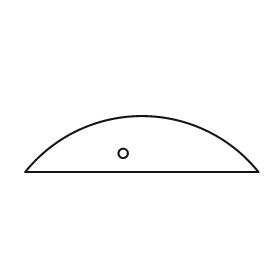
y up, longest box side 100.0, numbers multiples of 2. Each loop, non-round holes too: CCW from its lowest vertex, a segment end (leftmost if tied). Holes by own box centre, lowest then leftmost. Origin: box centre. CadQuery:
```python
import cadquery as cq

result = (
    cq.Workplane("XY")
    .moveTo(-50.0, -12.0)
    .lineTo(50.0, -12.0)
    .threePointArc((0.0, 12.0), (-50.0, -12.0))
    .close()
    .moveTo(-8.0, -4.0)
    .circle(2.0)
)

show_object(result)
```